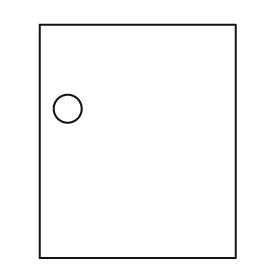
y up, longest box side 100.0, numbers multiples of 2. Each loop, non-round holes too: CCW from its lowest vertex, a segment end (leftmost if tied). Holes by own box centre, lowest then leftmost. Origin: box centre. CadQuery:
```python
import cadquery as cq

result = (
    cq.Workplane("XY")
    .moveTo(-42.0, -50.0)
    .lineTo(42.0, -50.0)
    .lineTo(42.0, 50.0)
    .lineTo(-42.0, 50.0)
    .close()
    .moveTo(-30.0, 14.0)
    .circle(6.0)
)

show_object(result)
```